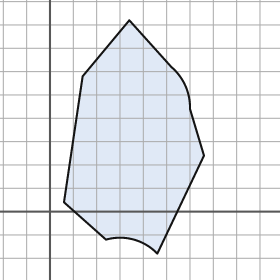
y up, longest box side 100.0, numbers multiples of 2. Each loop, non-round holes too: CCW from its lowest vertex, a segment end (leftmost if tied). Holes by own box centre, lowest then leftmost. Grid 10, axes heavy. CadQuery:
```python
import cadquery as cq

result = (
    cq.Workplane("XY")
    .moveTo(46.0, -18.0)
    .lineTo(66.0, 24.0)
    .lineTo(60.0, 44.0)
    .threePointArc((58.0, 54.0), (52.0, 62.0))
    .lineTo(34.0, 82.0)
    .lineTo(14.0, 58.0)
    .lineTo(6.0, 4.0)
    .lineTo(24.0, -12.0)
    .threePointArc((36.0, -12.0), (46.0, -18.0))
    .close()
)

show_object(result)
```